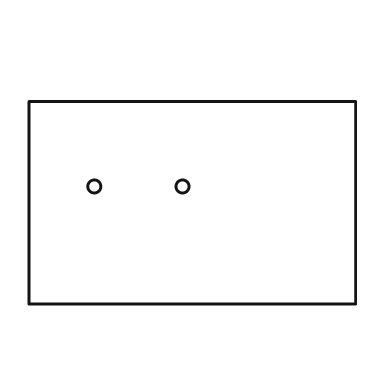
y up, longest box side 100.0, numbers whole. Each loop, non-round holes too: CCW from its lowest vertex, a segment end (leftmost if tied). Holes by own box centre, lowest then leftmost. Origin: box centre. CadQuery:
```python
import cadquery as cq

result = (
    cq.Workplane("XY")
    .moveTo(-50.0, -31.0)
    .lineTo(50.0, -31.0)
    .lineTo(50.0, 31.0)
    .lineTo(-50.0, 31.0)
    .close()
    .moveTo(-30.0, 5.0)
    .circle(2.0)
    .moveTo(-3.0, 5.0)
    .circle(2.0)
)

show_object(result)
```